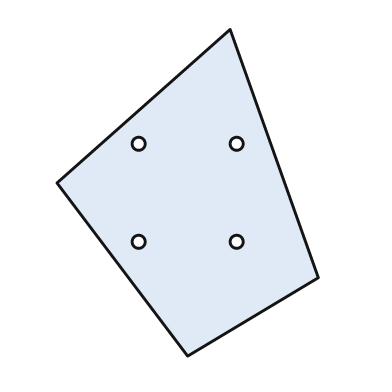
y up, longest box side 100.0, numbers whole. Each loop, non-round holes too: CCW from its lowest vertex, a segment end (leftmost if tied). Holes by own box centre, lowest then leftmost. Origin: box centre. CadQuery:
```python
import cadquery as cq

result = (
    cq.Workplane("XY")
    .moveTo(0.0, -50.0)
    .lineTo(40.0, -26.0)
    .lineTo(13.0, 50.0)
    .lineTo(-40.0, 3.0)
    .close()
    .moveTo(-15.0, -15.0)
    .circle(2.0)
    .moveTo(15.0, -15.0)
    .circle(2.0)
    .moveTo(-15.0, 15.0)
    .circle(2.0)
    .moveTo(15.0, 15.0)
    .circle(2.0)
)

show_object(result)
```